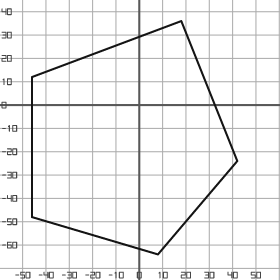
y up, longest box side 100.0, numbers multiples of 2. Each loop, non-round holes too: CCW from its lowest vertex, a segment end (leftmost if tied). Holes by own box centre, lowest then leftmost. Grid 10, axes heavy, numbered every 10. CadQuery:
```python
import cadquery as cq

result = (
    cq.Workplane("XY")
    .moveTo(8.0, -64.0)
    .lineTo(42.0, -24.0)
    .lineTo(18.0, 36.0)
    .lineTo(-46.0, 12.0)
    .lineTo(-46.0, -48.0)
    .close()
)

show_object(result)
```